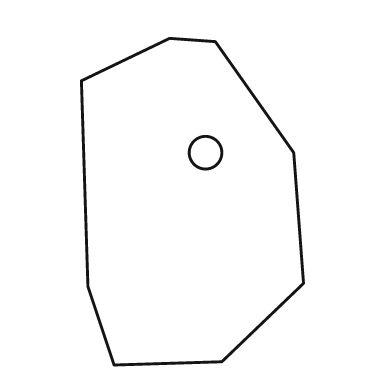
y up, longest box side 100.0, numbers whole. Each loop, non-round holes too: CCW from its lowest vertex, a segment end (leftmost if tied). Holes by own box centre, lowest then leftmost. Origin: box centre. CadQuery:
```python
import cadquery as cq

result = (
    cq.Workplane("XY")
    .moveTo(-24.0, -50.0)
    .lineTo(9.0, -49.0)
    .lineTo(34.0, -25.0)
    .lineTo(31.0, 15.0)
    .lineTo(7.0, 49.0)
    .lineTo(-7.0, 50.0)
    .lineTo(-34.0, 37.0)
    .lineTo(-32.0, -26.0)
    .close()
    .moveTo(4.0, 15.0)
    .circle(5.0)
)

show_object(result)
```